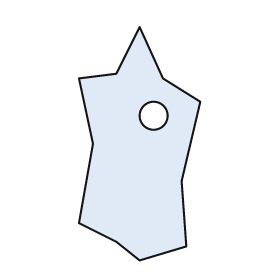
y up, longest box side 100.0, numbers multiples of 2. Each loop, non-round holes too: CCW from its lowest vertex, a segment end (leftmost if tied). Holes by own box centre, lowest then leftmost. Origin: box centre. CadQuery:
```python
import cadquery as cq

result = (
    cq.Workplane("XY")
    .moveTo(0.0, -50.0)
    .lineTo(20.0, -44.0)
    .lineTo(18.0, -16.0)
    .lineTo(26.0, 18.0)
    .lineTo(10.0, 28.0)
    .lineTo(0.0, 50.0)
    .lineTo(-10.0, 30.0)
    .lineTo(-26.0, 28.0)
    .lineTo(-20.0, 0.0)
    .lineTo(-26.0, -34.0)
    .lineTo(-10.0, -42.0)
    .close()
    .moveTo(6.0, 12.0)
    .circle(6.0)
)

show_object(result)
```